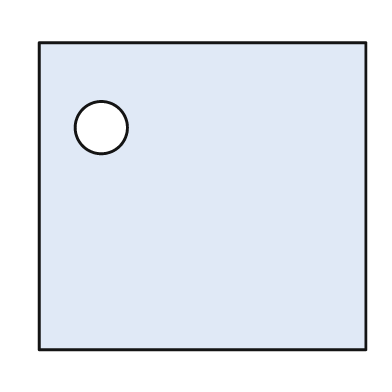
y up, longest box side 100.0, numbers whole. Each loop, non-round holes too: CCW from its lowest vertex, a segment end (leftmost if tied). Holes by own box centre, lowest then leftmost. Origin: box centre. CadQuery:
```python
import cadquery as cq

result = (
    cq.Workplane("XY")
    .moveTo(-50.0, -47.0)
    .lineTo(50.0, -47.0)
    .lineTo(50.0, 47.0)
    .lineTo(-50.0, 47.0)
    .close()
    .moveTo(-31.0, 21.0)
    .circle(8.0)
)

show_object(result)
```